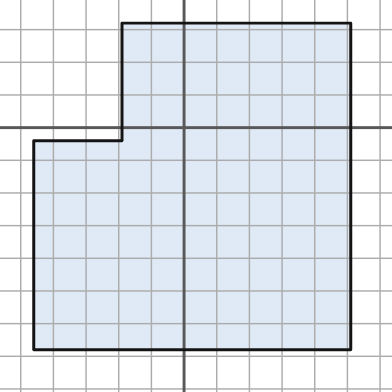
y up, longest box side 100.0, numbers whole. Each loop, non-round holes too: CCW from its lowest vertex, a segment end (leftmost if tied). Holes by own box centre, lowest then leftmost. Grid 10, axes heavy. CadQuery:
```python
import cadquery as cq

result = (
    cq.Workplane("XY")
    .moveTo(-46.0, -68.0)
    .lineTo(51.0, -68.0)
    .lineTo(51.0, 32.0)
    .lineTo(-19.0, 32.0)
    .lineTo(-19.0, -4.0)
    .lineTo(-46.0, -4.0)
    .close()
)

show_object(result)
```